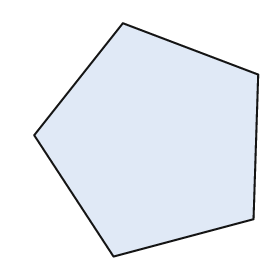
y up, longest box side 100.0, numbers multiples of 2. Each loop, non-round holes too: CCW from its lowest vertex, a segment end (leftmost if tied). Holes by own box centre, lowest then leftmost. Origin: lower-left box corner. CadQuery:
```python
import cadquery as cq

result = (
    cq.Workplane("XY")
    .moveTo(34.0, 0.0)
    .lineTo(94.0, 16.0)
    .lineTo(96.0, 78.0)
    .lineTo(38.0, 100.0)
    .lineTo(0.0, 52.0)
    .close()
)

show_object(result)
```